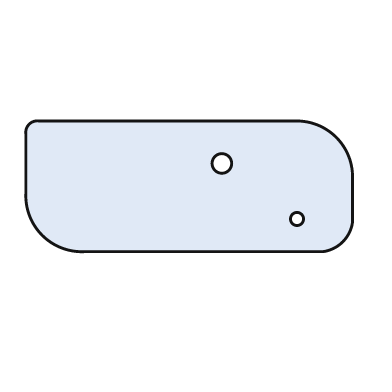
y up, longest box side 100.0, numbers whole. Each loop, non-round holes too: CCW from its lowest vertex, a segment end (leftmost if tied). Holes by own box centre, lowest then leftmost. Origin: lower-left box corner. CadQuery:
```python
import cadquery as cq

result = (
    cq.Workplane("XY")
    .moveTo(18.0, 0.0)
    .lineTo(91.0, 0.0)
    .threePointArc((97.0, 3.0), (100.0, 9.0))
    .lineTo(100.0, 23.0)
    .threePointArc((95.0, 35.0), (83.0, 40.0))
    .lineTo(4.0, 40.0)
    .threePointArc((1.0, 39.0), (0.0, 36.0))
    .lineTo(0.0, 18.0)
    .threePointArc((5.0, 5.0), (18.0, 0.0))
    .close()
    .moveTo(83.0, 10.0)
    .circle(2.0)
    .moveTo(60.0, 27.0)
    .circle(3.0)
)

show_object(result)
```